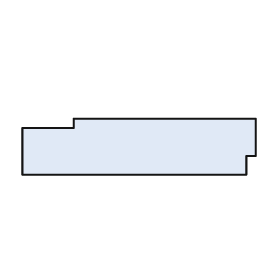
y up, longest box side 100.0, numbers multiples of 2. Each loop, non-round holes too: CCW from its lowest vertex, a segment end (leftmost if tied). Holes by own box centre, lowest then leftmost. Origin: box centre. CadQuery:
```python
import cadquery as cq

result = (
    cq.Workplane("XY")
    .moveTo(-50.0, -12.0)
    .lineTo(46.0, -12.0)
    .lineTo(46.0, -4.0)
    .lineTo(50.0, -4.0)
    .lineTo(50.0, 12.0)
    .lineTo(-28.0, 12.0)
    .lineTo(-28.0, 8.0)
    .lineTo(-50.0, 8.0)
    .close()
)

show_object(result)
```